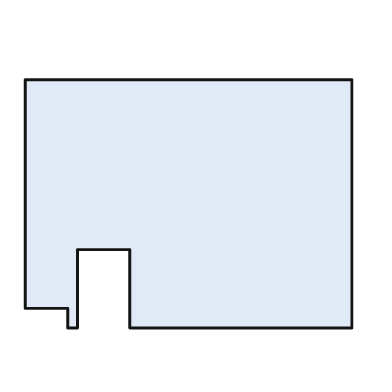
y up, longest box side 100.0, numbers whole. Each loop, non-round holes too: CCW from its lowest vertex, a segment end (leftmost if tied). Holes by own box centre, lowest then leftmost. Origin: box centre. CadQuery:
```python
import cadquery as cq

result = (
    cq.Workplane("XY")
    .moveTo(-37.0, -38.0)
    .lineTo(-34.0, -38.0)
    .lineTo(-34.0, -14.0)
    .lineTo(-18.0, -14.0)
    .lineTo(-18.0, -38.0)
    .lineTo(50.0, -38.0)
    .lineTo(50.0, 38.0)
    .lineTo(-50.0, 38.0)
    .lineTo(-50.0, -32.0)
    .lineTo(-37.0, -32.0)
    .close()
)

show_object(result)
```